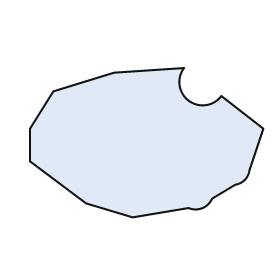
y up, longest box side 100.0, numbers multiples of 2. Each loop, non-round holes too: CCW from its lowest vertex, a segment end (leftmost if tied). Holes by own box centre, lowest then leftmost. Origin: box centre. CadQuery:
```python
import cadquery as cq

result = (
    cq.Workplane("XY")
    .moveTo(-6.0, -32.0)
    .lineTo(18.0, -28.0)
    .threePointArc((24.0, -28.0), (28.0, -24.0))
    .lineTo(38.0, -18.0)
    .threePointArc((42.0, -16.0), (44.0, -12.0))
    .lineTo(50.0, 6.0)
    .lineTo(32.0, 20.0)
    .threePointArc((18.0, 18.0), (16.0, 32.0))
    .lineTo(-14.0, 30.0)
    .lineTo(-40.0, 22.0)
    .lineTo(-50.0, 6.0)
    .lineTo(-50.0, -8.0)
    .lineTo(-26.0, -26.0)
    .close()
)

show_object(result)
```